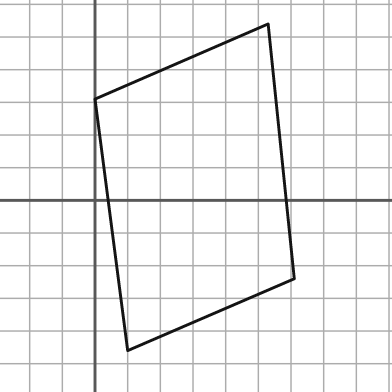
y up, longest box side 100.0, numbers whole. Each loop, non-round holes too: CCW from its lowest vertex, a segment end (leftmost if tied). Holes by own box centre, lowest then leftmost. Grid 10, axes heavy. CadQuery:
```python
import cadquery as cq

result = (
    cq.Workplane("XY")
    .moveTo(10.0, -46.0)
    .lineTo(61.0, -24.0)
    .lineTo(53.0, 54.0)
    .lineTo(0.0, 31.0)
    .close()
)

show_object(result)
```